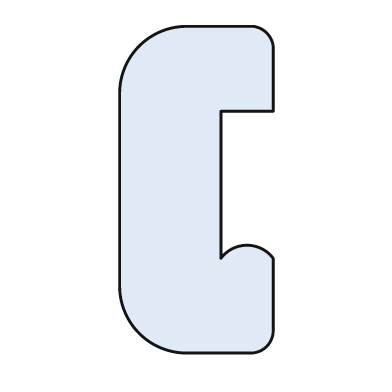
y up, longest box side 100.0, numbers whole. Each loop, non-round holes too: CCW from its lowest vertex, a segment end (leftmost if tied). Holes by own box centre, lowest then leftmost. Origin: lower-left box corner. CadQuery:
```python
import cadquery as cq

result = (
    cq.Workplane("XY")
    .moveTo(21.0, 0.0)
    .lineTo(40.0, 0.0)
    .threePointArc((45.0, 2.0), (47.0, 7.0))
    .lineTo(47.0, 29.0)
    .threePointArc((39.0, 33.0), (31.0, 29.0))
    .lineTo(31.0, 74.0)
    .lineTo(47.0, 74.0)
    .lineTo(47.0, 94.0)
    .threePointArc((45.0, 98.0), (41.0, 100.0))
    .lineTo(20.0, 100.0)
    .threePointArc((6.0, 94.0), (0.0, 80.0))
    .lineTo(0.0, 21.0)
    .threePointArc((6.0, 6.0), (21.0, 0.0))
    .close()
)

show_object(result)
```